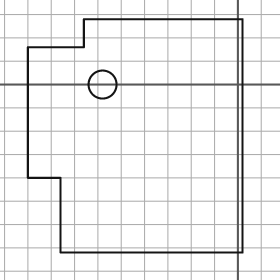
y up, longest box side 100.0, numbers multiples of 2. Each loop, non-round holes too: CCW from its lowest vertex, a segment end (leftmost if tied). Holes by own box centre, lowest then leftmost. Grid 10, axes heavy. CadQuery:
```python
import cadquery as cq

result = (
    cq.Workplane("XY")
    .moveTo(-76.0, -72.0)
    .lineTo(2.0, -72.0)
    .lineTo(2.0, 28.0)
    .lineTo(-66.0, 28.0)
    .lineTo(-66.0, 16.0)
    .lineTo(-90.0, 16.0)
    .lineTo(-90.0, -40.0)
    .lineTo(-76.0, -40.0)
    .close()
    .moveTo(-58.0, 0.0)
    .circle(6.0)
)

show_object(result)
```